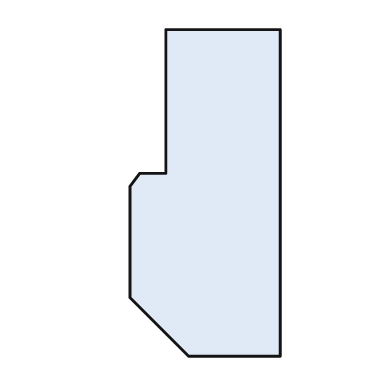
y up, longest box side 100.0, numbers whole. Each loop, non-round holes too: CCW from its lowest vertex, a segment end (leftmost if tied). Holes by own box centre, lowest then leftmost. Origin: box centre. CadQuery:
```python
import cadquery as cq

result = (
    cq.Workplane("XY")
    .moveTo(-5.0, -50.0)
    .lineTo(23.0, -50.0)
    .lineTo(23.0, 50.0)
    .lineTo(-12.0, 50.0)
    .lineTo(-12.0, 6.0)
    .lineTo(-20.0, 6.0)
    .lineTo(-23.0, 2.0)
    .lineTo(-23.0, -32.0)
    .close()
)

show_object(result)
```